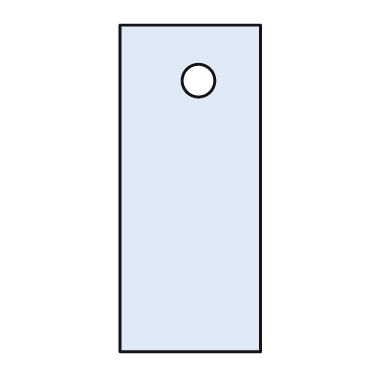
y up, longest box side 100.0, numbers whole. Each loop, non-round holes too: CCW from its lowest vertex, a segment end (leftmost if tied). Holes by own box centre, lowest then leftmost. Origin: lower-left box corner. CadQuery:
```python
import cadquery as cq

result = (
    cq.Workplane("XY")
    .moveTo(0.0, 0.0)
    .lineTo(43.0, 0.0)
    .lineTo(43.0, 100.0)
    .lineTo(0.0, 100.0)
    .close()
    .moveTo(24.0, 83.0)
    .circle(5.0)
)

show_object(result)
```